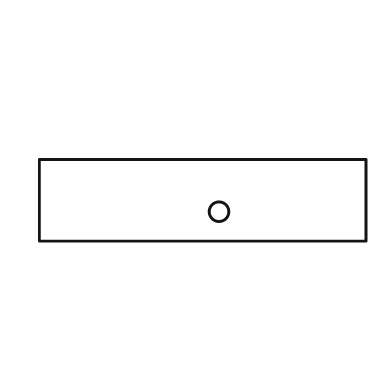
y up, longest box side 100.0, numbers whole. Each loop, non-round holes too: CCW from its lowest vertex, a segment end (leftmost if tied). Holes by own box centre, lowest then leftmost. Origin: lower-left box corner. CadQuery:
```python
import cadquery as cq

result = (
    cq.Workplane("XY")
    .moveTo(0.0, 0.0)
    .lineTo(100.0, 0.0)
    .lineTo(100.0, 25.0)
    .lineTo(0.0, 25.0)
    .close()
    .moveTo(55.0, 9.0)
    .circle(3.0)
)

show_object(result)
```